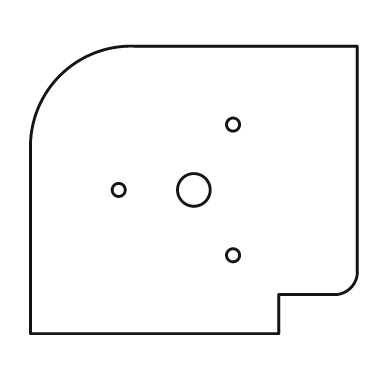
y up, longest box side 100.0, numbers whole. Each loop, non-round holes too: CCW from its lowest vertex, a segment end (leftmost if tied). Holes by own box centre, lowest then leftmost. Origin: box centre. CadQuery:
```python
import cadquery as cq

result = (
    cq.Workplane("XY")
    .moveTo(-50.0, -44.0)
    .lineTo(26.0, -44.0)
    .lineTo(26.0, -32.0)
    .lineTo(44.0, -32.0)
    .threePointArc((48.0, -30.0), (50.0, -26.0))
    .lineTo(50.0, 44.0)
    .lineTo(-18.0, 44.0)
    .threePointArc((-41.0, 35.0), (-50.0, 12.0))
    .close()
    .moveTo(12.0, -20.0)
    .circle(2.0)
    .moveTo(-23.0, 0.0)
    .circle(2.0)
    .moveTo(0.0, 0.0)
    .circle(5.0)
    .moveTo(12.0, 20.0)
    .circle(2.0)
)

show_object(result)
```